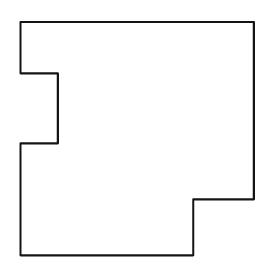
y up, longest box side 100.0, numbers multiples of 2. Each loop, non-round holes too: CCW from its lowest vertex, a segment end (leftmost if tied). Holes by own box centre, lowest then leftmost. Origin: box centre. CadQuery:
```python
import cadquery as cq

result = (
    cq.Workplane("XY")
    .moveTo(-50.0, -50.0)
    .lineTo(24.0, -50.0)
    .lineTo(24.0, -26.0)
    .lineTo(50.0, -26.0)
    .lineTo(50.0, 50.0)
    .lineTo(-50.0, 50.0)
    .lineTo(-50.0, 28.0)
    .lineTo(-34.0, 28.0)
    .lineTo(-34.0, -2.0)
    .lineTo(-50.0, -2.0)
    .close()
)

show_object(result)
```